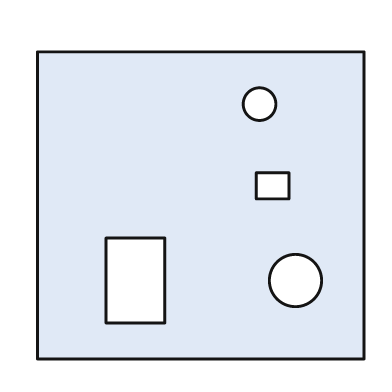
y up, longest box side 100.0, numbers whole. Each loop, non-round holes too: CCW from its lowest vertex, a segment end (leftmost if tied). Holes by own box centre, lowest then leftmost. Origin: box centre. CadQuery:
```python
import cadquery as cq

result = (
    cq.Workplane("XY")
    .moveTo(-50.0, -47.0)
    .lineTo(50.0, -47.0)
    .lineTo(50.0, 47.0)
    .lineTo(-50.0, 47.0)
    .close()
    .moveTo(-29.0, -36.0)
    .lineTo(-11.0, -36.0)
    .lineTo(-11.0, -10.0)
    .lineTo(-29.0, -10.0)
    .close()
    .moveTo(29.0, -23.0)
    .circle(8.0)
    .moveTo(17.0, 2.0)
    .lineTo(27.0, 2.0)
    .lineTo(27.0, 10.0)
    .lineTo(17.0, 10.0)
    .close()
    .moveTo(18.0, 31.0)
    .circle(5.0)
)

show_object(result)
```